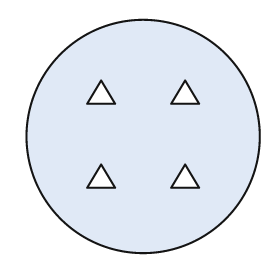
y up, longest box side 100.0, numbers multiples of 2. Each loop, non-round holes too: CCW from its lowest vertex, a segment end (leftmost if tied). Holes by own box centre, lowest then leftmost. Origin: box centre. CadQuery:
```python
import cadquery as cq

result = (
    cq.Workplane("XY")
    .moveTo(0.0, 0.0)
    .circle(50.0)
    .moveTo(-24.0, -22.0)
    .lineTo(-12.0, -22.0)
    .lineTo(-18.0, -12.0)
    .close()
    .moveTo(12.0, -22.0)
    .lineTo(24.0, -22.0)
    .lineTo(18.0, -12.0)
    .close()
    .moveTo(-24.0, 14.0)
    .lineTo(-12.0, 14.0)
    .lineTo(-18.0, 24.0)
    .close()
    .moveTo(12.0, 14.0)
    .lineTo(24.0, 14.0)
    .lineTo(18.0, 24.0)
    .close()
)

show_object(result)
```